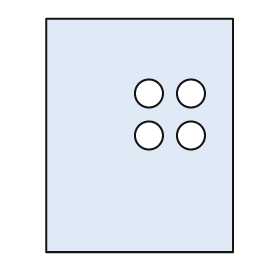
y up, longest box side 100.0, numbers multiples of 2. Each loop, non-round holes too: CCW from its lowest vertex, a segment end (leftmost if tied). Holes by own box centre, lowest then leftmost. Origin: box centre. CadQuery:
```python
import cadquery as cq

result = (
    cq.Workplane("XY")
    .moveTo(-40.0, -50.0)
    .lineTo(40.0, -50.0)
    .lineTo(40.0, 50.0)
    .lineTo(-40.0, 50.0)
    .close()
    .moveTo(4.0, 0.0)
    .circle(6.0)
    .moveTo(22.0, 0.0)
    .circle(6.0)
    .moveTo(4.0, 18.0)
    .circle(6.0)
    .moveTo(22.0, 18.0)
    .circle(6.0)
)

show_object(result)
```